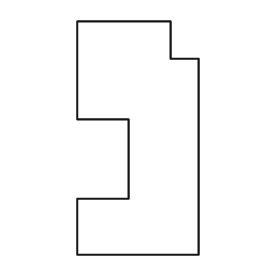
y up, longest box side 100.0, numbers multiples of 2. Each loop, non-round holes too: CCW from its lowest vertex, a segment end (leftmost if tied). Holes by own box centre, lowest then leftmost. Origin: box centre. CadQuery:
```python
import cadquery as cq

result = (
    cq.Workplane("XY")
    .moveTo(-26.0, -50.0)
    .lineTo(26.0, -50.0)
    .lineTo(26.0, 34.0)
    .lineTo(14.0, 34.0)
    .lineTo(14.0, 50.0)
    .lineTo(-26.0, 50.0)
    .lineTo(-26.0, 8.0)
    .lineTo(-4.0, 8.0)
    .lineTo(-4.0, -26.0)
    .lineTo(-26.0, -26.0)
    .close()
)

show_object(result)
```